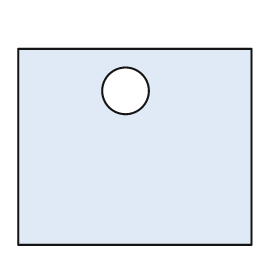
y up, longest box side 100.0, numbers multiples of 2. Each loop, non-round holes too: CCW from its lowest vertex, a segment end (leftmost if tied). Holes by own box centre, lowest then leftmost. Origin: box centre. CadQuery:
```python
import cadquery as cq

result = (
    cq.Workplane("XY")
    .moveTo(-50.0, -42.0)
    .lineTo(50.0, -42.0)
    .lineTo(50.0, 42.0)
    .lineTo(-50.0, 42.0)
    .close()
    .moveTo(-4.0, 24.0)
    .circle(10.0)
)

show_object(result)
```